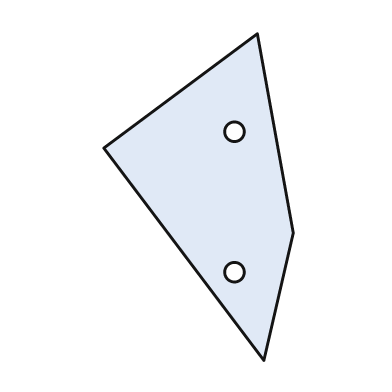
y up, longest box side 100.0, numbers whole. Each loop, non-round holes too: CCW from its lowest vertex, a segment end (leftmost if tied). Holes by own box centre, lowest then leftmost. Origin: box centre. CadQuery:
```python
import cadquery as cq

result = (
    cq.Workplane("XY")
    .moveTo(20.0, -50.0)
    .lineTo(29.0, -11.0)
    .lineTo(18.0, 50.0)
    .lineTo(-29.0, 15.0)
    .close()
    .moveTo(11.0, -23.0)
    .circle(3.0)
    .moveTo(11.0, 20.0)
    .circle(3.0)
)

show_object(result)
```